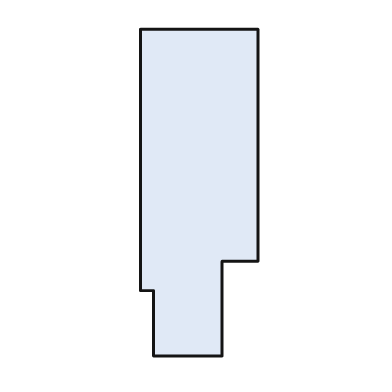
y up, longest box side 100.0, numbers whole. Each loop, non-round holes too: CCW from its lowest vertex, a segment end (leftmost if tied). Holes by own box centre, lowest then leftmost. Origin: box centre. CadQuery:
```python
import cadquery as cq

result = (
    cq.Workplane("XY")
    .moveTo(-14.0, -50.0)
    .lineTo(7.0, -50.0)
    .lineTo(7.0, -21.0)
    .lineTo(18.0, -21.0)
    .lineTo(18.0, 50.0)
    .lineTo(-18.0, 50.0)
    .lineTo(-18.0, -30.0)
    .lineTo(-14.0, -30.0)
    .close()
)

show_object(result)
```